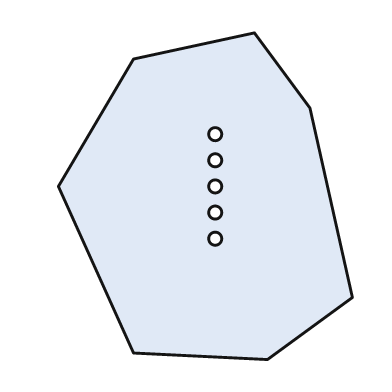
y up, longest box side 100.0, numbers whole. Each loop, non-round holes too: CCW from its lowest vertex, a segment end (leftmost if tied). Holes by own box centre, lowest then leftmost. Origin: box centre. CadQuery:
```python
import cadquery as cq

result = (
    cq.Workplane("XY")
    .moveTo(19.0, -50.0)
    .lineTo(45.0, -31.0)
    .lineTo(32.0, 27.0)
    .lineTo(15.0, 50.0)
    .lineTo(-22.0, 42.0)
    .lineTo(-45.0, 3.0)
    .lineTo(-22.0, -48.0)
    .close()
    .moveTo(3.0, -13.0)
    .circle(2.0)
    .moveTo(3.0, -5.0)
    .circle(2.0)
    .moveTo(3.0, 3.0)
    .circle(2.0)
    .moveTo(3.0, 11.0)
    .circle(2.0)
    .moveTo(3.0, 19.0)
    .circle(2.0)
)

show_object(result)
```